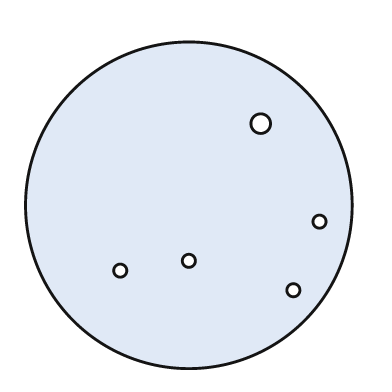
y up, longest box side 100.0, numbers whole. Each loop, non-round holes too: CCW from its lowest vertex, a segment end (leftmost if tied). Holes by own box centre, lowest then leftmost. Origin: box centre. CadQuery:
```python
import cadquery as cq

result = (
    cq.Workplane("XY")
    .moveTo(0.0, 0.0)
    .circle(50.0)
    .moveTo(32.0, -26.0)
    .circle(2.0)
    .moveTo(-21.0, -20.0)
    .circle(2.0)
    .moveTo(0.0, -17.0)
    .circle(2.0)
    .moveTo(40.0, -5.0)
    .circle(2.0)
    .moveTo(22.0, 25.0)
    .circle(3.0)
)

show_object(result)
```